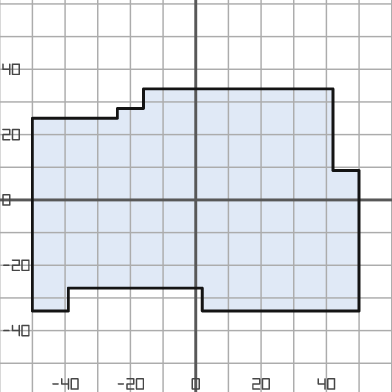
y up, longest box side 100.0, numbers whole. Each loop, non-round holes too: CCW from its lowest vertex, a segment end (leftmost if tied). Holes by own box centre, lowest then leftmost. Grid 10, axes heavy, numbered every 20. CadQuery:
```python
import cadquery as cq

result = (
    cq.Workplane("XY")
    .moveTo(-50.0, -34.0)
    .lineTo(-39.0, -34.0)
    .lineTo(-39.0, -27.0)
    .lineTo(2.0, -27.0)
    .lineTo(2.0, -34.0)
    .lineTo(50.0, -34.0)
    .lineTo(50.0, 9.0)
    .lineTo(42.0, 9.0)
    .lineTo(42.0, 34.0)
    .lineTo(-16.0, 34.0)
    .lineTo(-16.0, 28.0)
    .lineTo(-24.0, 28.0)
    .lineTo(-24.0, 25.0)
    .lineTo(-50.0, 25.0)
    .close()
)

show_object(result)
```